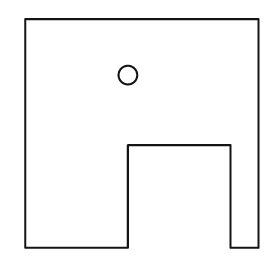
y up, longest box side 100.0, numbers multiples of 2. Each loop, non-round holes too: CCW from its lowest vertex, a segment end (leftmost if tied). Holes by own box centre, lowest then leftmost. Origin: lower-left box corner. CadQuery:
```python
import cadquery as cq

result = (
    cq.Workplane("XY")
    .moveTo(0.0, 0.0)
    .lineTo(44.0, 0.0)
    .lineTo(44.0, 44.0)
    .lineTo(88.0, 44.0)
    .lineTo(88.0, 0.0)
    .lineTo(100.0, 0.0)
    .lineTo(100.0, 98.0)
    .lineTo(0.0, 98.0)
    .close()
    .moveTo(44.0, 74.0)
    .circle(4.0)
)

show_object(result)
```